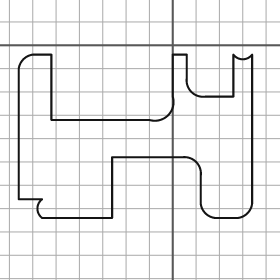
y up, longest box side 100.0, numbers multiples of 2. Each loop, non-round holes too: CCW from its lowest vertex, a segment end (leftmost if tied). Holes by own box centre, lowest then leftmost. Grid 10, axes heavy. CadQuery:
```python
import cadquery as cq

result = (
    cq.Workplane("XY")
    .moveTo(-56.0, -74.0)
    .lineTo(-26.0, -74.0)
    .lineTo(-26.0, -48.0)
    .lineTo(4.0, -48.0)
    .threePointArc((10.0, -50.0), (12.0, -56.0))
    .lineTo(12.0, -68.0)
    .threePointArc((14.0, -72.0), (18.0, -74.0))
    .lineTo(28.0, -74.0)
    .threePointArc((32.0, -72.0), (34.0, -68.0))
    .lineTo(34.0, -4.0)
    .threePointArc((30.0, -6.0), (26.0, -4.0))
    .lineTo(26.0, -22.0)
    .lineTo(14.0, -22.0)
    .threePointArc((8.0, -20.0), (6.0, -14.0))
    .lineTo(6.0, -4.0)
    .lineTo(0.0, -4.0)
    .lineTo(0.0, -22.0)
    .threePointArc((-2.0, -30.0), (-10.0, -32.0))
    .lineTo(-52.0, -32.0)
    .lineTo(-52.0, -4.0)
    .lineTo(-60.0, -4.0)
    .threePointArc((-64.0, -6.0), (-66.0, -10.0))
    .lineTo(-66.0, -66.0)
    .lineTo(-56.0, -66.0)
    .threePointArc((-58.0, -70.0), (-56.0, -74.0))
    .close()
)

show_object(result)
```